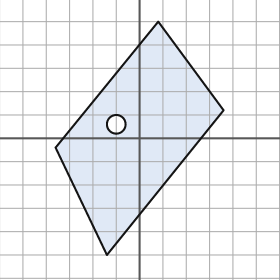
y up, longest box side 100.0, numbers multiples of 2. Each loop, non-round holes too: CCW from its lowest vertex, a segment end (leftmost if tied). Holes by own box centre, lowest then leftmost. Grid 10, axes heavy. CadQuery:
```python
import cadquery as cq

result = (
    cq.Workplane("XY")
    .moveTo(-14.0, -50.0)
    .lineTo(36.0, 12.0)
    .lineTo(8.0, 50.0)
    .lineTo(-36.0, -4.0)
    .close()
    .moveTo(-10.0, 6.0)
    .circle(4.0)
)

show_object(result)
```